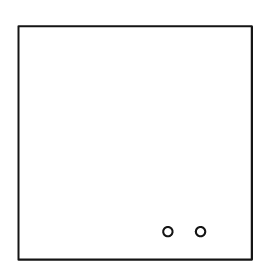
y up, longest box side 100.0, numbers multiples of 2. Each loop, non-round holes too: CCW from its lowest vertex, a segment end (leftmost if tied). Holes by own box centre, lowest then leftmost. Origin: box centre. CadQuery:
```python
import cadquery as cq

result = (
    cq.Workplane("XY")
    .moveTo(-50.0, -50.0)
    .lineTo(50.0, -50.0)
    .lineTo(50.0, 50.0)
    .lineTo(-50.0, 50.0)
    .close()
    .moveTo(14.0, -38.0)
    .circle(2.0)
    .moveTo(28.0, -38.0)
    .circle(2.0)
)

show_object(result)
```